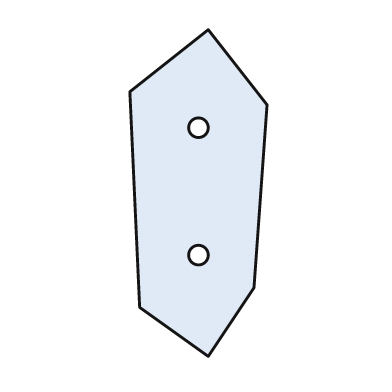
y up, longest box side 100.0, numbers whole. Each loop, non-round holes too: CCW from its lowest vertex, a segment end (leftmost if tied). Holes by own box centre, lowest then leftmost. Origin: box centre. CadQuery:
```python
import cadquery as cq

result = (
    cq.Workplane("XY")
    .moveTo(3.0, -50.0)
    .lineTo(17.0, -29.0)
    .lineTo(21.0, 27.0)
    .lineTo(3.0, 50.0)
    .lineTo(-21.0, 31.0)
    .lineTo(-18.0, -35.0)
    .close()
    .moveTo(0.0, -19.0)
    .circle(3.0)
    .moveTo(0.0, 20.0)
    .circle(3.0)
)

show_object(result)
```